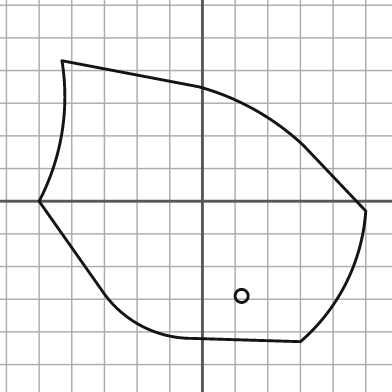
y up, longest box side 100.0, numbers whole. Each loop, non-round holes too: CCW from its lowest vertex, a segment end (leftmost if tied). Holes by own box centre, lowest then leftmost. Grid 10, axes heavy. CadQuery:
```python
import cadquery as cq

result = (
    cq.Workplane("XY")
    .moveTo(30.0, -43.0)
    .threePointArc((44.0, -25.0), (50.0, -3.0))
    .lineTo(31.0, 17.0)
    .threePointArc((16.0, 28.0), (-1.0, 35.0))
    .lineTo(-43.0, 43.0)
    .threePointArc((-43.0, 21.0), (-50.0, 0.0))
    .lineTo(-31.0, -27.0)
    .threePointArc((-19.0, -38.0), (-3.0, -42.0))
    .close()
    .moveTo(12.0, -29.0)
    .circle(2.0)
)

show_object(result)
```